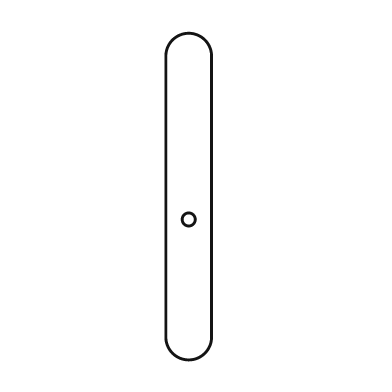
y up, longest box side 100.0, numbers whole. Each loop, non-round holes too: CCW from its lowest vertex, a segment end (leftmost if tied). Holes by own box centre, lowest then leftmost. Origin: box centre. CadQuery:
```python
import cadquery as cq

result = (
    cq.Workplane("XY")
    .moveTo(-7.0, -43.0)
    .threePointArc((0.0, -50.0), (7.0, -43.0))
    .lineTo(7.0, 43.0)
    .threePointArc((0.0, 50.0), (-7.0, 43.0))
    .close()
    .moveTo(0.0, -7.0)
    .circle(2.0)
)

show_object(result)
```